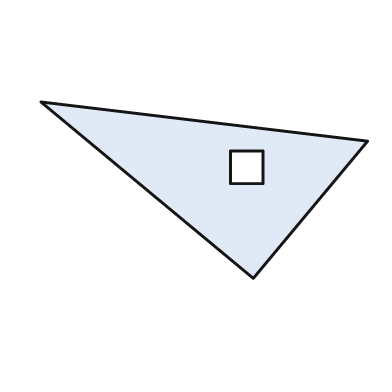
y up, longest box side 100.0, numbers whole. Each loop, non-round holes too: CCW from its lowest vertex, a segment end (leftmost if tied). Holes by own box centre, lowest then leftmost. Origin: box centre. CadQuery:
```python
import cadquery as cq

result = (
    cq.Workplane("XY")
    .moveTo(15.0, -27.0)
    .lineTo(50.0, 15.0)
    .lineTo(-50.0, 27.0)
    .close()
    .moveTo(8.0, 2.0)
    .lineTo(18.0, 2.0)
    .lineTo(18.0, 12.0)
    .lineTo(8.0, 12.0)
    .close()
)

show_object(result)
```